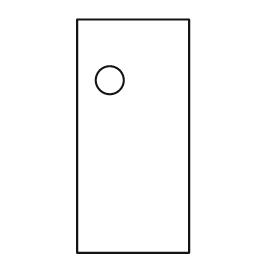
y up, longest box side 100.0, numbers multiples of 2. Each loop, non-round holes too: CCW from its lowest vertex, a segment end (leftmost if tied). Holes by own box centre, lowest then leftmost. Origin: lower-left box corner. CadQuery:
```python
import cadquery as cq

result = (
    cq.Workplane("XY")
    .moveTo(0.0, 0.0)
    .lineTo(48.0, 0.0)
    .lineTo(48.0, 100.0)
    .lineTo(0.0, 100.0)
    .close()
    .moveTo(14.0, 74.0)
    .circle(6.0)
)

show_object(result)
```